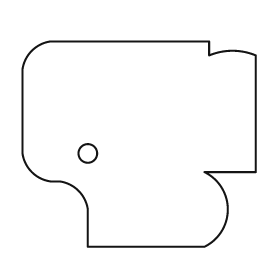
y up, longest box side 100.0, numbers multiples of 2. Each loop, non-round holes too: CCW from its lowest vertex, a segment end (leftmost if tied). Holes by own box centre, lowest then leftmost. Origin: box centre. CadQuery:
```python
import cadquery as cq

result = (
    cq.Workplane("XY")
    .moveTo(-22.0, -44.0)
    .lineTo(28.0, -44.0)
    .threePointArc((38.0, -28.0), (28.0, -12.0))
    .lineTo(50.0, -12.0)
    .lineTo(50.0, 38.0)
    .threePointArc((40.0, 40.0), (30.0, 38.0))
    .lineTo(30.0, 44.0)
    .lineTo(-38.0, 44.0)
    .threePointArc((-46.0, 40.0), (-50.0, 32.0))
    .lineTo(-50.0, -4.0)
    .threePointArc((-46.0, -12.0), (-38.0, -16.0))
    .lineTo(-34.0, -16.0)
    .threePointArc((-26.0, -20.0), (-22.0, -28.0))
    .close()
    .moveTo(-22.0, -4.0)
    .circle(4.0)
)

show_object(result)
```